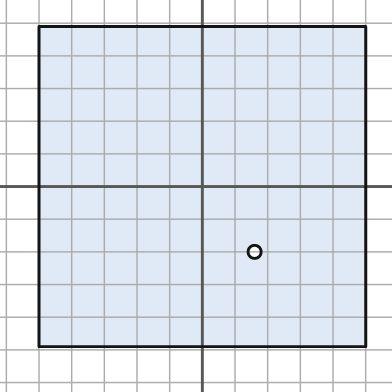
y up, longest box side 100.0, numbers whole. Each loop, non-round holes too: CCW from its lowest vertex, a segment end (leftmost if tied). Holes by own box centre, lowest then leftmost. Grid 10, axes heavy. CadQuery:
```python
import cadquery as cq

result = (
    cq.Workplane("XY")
    .moveTo(-50.0, -49.0)
    .lineTo(50.0, -49.0)
    .lineTo(50.0, 49.0)
    .lineTo(-50.0, 49.0)
    .close()
    .moveTo(16.0, -20.0)
    .circle(2.0)
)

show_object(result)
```